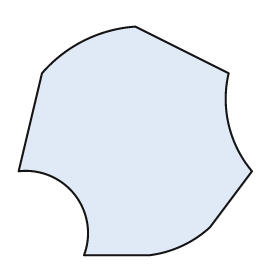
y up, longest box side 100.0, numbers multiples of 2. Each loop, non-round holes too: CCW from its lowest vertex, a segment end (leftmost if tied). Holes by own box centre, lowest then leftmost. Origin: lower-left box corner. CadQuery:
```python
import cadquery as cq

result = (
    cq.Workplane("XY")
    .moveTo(28.0, 0.0)
    .lineTo(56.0, 0.0)
    .threePointArc((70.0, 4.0), (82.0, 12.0))
    .lineTo(100.0, 36.0)
    .threePointArc((90.0, 56.0), (90.0, 78.0))
    .lineTo(50.0, 98.0)
    .threePointArc((28.0, 92.0), (10.0, 78.0))
    .lineTo(0.0, 36.0)
    .threePointArc((24.0, 26.0), (28.0, 0.0))
    .close()
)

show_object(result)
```